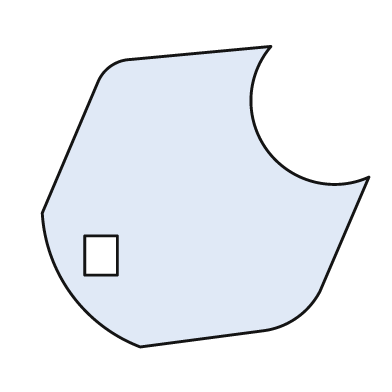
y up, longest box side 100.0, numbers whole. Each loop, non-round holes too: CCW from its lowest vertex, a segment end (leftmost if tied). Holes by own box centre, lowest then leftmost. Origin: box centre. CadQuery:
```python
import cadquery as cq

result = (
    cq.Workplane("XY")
    .moveTo(-20.0, -46.0)
    .lineTo(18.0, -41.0)
    .threePointArc((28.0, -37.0), (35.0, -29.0))
    .lineTo(50.0, 6.0)
    .threePointArc((19.0, 14.0), (20.0, 46.0))
    .lineTo(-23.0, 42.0)
    .threePointArc((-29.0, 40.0), (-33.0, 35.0))
    .lineTo(-50.0, -5.0)
    .threePointArc((-41.0, -30.0), (-20.0, -46.0))
    .close()
    .moveTo(-37.0, -24.0)
    .lineTo(-27.0, -24.0)
    .lineTo(-27.0, -12.0)
    .lineTo(-37.0, -12.0)
    .close()
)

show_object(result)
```